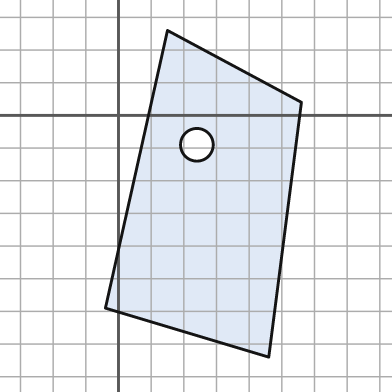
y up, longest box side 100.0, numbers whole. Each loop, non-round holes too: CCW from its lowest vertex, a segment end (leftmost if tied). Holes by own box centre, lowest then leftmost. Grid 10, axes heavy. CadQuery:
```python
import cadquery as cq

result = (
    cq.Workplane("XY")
    .moveTo(46.0, -74.0)
    .lineTo(56.0, 4.0)
    .lineTo(15.0, 26.0)
    .lineTo(-4.0, -59.0)
    .close()
    .moveTo(24.0, -9.0)
    .circle(5.0)
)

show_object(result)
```